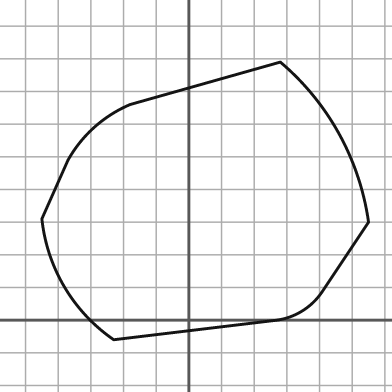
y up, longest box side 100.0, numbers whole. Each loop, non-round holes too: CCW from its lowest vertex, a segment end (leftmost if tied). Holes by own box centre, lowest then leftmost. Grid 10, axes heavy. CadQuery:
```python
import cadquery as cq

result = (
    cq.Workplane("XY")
    .moveTo(-23.0, -6.0)
    .lineTo(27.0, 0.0)
    .threePointArc((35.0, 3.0), (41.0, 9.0))
    .lineTo(55.0, 30.0)
    .threePointArc((46.0, 57.0), (28.0, 79.0))
    .lineTo(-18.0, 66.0)
    .threePointArc((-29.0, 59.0), (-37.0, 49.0))
    .lineTo(-45.0, 31.0)
    .threePointArc((-38.0, 10.0), (-23.0, -6.0))
    .close()
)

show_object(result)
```